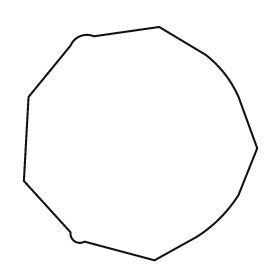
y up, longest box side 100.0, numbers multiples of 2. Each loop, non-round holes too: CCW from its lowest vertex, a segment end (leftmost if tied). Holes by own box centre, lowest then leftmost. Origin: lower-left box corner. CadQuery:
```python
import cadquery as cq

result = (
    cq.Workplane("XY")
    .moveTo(56.0, 0.0)
    .lineTo(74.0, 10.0)
    .threePointArc((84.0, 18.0), (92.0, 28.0))
    .lineTo(100.0, 48.0)
    .lineTo(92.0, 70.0)
    .threePointArc((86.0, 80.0), (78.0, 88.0))
    .lineTo(58.0, 100.0)
    .lineTo(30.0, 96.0)
    .threePointArc((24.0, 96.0), (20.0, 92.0))
    .lineTo(2.0, 70.0)
    .lineTo(0.0, 34.0)
    .lineTo(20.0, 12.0)
    .threePointArc((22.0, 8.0), (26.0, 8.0))
    .close()
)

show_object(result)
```